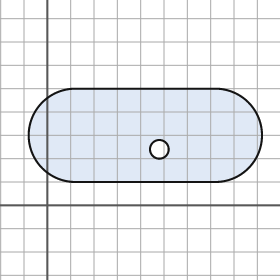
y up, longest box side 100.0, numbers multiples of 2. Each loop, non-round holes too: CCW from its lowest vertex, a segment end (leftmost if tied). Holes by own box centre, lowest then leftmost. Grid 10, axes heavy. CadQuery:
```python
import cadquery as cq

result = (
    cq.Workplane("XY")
    .moveTo(12.0, 10.0)
    .lineTo(72.0, 10.0)
    .threePointArc((92.0, 30.0), (72.0, 50.0))
    .lineTo(12.0, 50.0)
    .threePointArc((-8.0, 30.0), (12.0, 10.0))
    .close()
    .moveTo(48.0, 24.0)
    .circle(4.0)
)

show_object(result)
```